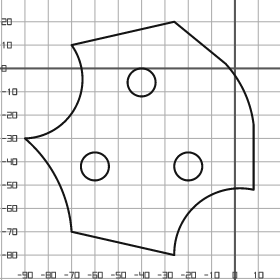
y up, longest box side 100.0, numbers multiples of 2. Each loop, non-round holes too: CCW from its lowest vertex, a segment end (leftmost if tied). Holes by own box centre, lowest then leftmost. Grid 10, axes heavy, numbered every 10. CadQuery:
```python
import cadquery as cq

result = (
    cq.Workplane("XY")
    .moveTo(-26.0, -80.0)
    .threePointArc((-16.0, -58.0), (8.0, -52.0))
    .lineTo(8.0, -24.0)
    .threePointArc((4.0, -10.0), (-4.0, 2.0))
    .lineTo(-26.0, 20.0)
    .lineTo(-70.0, 10.0)
    .threePointArc((-68.0, -16.0), (-90.0, -30.0))
    .threePointArc((-76.0, -48.0), (-70.0, -70.0))
    .close()
    .moveTo(-60.0, -42.0)
    .circle(6.0)
    .moveTo(-20.0, -42.0)
    .circle(6.0)
    .moveTo(-40.0, -6.0)
    .circle(6.0)
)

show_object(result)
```